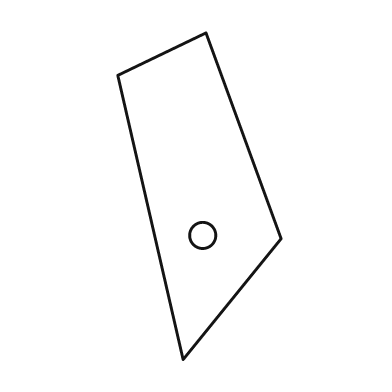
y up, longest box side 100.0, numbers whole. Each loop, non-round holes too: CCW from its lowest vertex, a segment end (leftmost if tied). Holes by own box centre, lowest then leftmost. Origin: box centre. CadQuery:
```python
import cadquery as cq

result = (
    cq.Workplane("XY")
    .moveTo(-5.0, -50.0)
    .lineTo(25.0, -13.0)
    .lineTo(2.0, 50.0)
    .lineTo(-25.0, 37.0)
    .close()
    .moveTo(1.0, -12.0)
    .circle(4.0)
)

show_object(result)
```